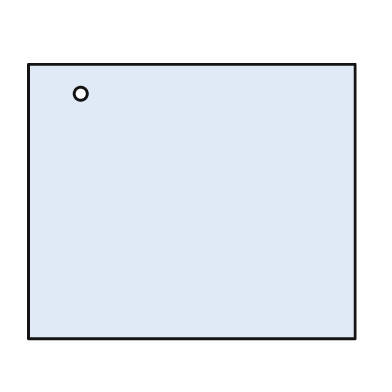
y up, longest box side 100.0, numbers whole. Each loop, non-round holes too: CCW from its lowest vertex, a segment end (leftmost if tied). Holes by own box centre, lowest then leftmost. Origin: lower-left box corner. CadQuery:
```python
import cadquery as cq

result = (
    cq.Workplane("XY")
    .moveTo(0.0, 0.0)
    .lineTo(100.0, 0.0)
    .lineTo(100.0, 84.0)
    .lineTo(0.0, 84.0)
    .close()
    .moveTo(16.0, 75.0)
    .circle(2.0)
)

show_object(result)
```